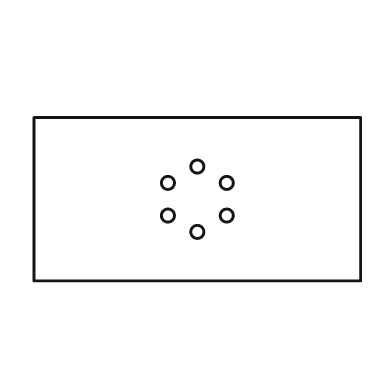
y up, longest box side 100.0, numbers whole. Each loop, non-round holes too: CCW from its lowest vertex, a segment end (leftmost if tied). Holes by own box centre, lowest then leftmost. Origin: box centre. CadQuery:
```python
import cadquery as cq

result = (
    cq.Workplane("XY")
    .moveTo(-50.0, -25.0)
    .lineTo(50.0, -25.0)
    .lineTo(50.0, 25.0)
    .lineTo(-50.0, 25.0)
    .close()
    .moveTo(0.0, -10.0)
    .circle(2.0)
    .moveTo(-9.0, -5.0)
    .circle(2.0)
    .moveTo(9.0, -5.0)
    .circle(2.0)
    .moveTo(-9.0, 5.0)
    .circle(2.0)
    .moveTo(9.0, 5.0)
    .circle(2.0)
    .moveTo(0.0, 10.0)
    .circle(2.0)
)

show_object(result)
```